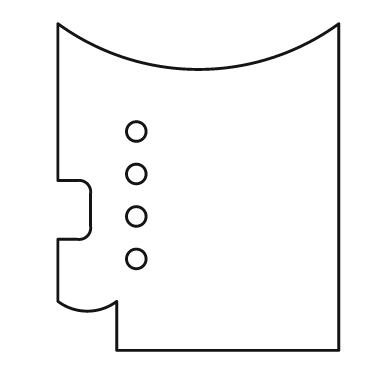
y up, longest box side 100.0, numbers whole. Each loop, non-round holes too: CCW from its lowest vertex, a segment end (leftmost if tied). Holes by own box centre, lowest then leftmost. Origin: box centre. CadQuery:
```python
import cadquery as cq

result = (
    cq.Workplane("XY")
    .moveTo(-25.0, -50.0)
    .lineTo(43.0, -50.0)
    .lineTo(43.0, 50.0)
    .threePointArc((0.0, 36.0), (-43.0, 50.0))
    .lineTo(-43.0, 2.0)
    .lineTo(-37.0, 2.0)
    .threePointArc((-34.0, 1.0), (-33.0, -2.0))
    .lineTo(-33.0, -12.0)
    .threePointArc((-34.0, -15.0), (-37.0, -16.0))
    .lineTo(-43.0, -16.0)
    .lineTo(-43.0, -35.0)
    .threePointArc((-34.0, -38.0), (-25.0, -35.0))
    .close()
    .moveTo(-19.0, -22.0)
    .circle(3.0)
    .moveTo(-19.0, -9.0)
    .circle(3.0)
    .moveTo(-19.0, 4.0)
    .circle(3.0)
    .moveTo(-19.0, 17.0)
    .circle(3.0)
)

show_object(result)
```